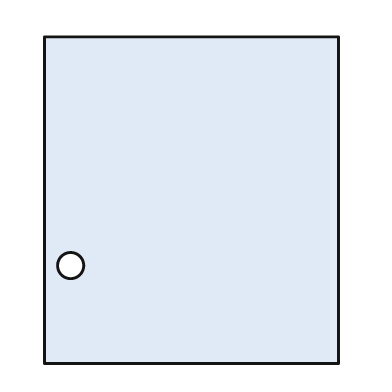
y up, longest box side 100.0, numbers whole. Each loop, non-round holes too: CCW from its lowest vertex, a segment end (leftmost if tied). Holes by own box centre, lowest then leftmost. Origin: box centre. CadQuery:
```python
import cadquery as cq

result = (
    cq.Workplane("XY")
    .moveTo(-45.0, -50.0)
    .lineTo(45.0, -50.0)
    .lineTo(45.0, 50.0)
    .lineTo(-45.0, 50.0)
    .close()
    .moveTo(-37.0, -20.0)
    .circle(4.0)
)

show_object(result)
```